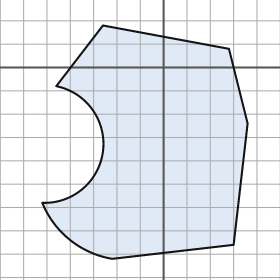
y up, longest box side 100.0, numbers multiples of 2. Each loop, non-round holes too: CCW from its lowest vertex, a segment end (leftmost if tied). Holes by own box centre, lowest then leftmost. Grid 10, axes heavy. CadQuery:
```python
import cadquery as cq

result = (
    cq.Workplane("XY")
    .moveTo(-22.0, -82.0)
    .lineTo(30.0, -76.0)
    .lineTo(36.0, -24.0)
    .lineTo(28.0, 8.0)
    .lineTo(-26.0, 18.0)
    .lineTo(-46.0, -8.0)
    .threePointArc((-26.0, -36.0), (-52.0, -58.0))
    .threePointArc((-40.0, -74.0), (-22.0, -82.0))
    .close()
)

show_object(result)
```